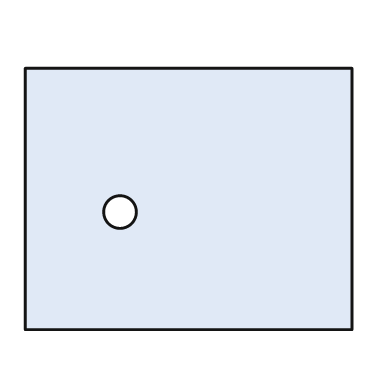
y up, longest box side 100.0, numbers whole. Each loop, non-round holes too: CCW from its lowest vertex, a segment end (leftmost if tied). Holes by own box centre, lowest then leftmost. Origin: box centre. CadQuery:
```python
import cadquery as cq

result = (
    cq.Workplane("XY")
    .moveTo(-50.0, -40.0)
    .lineTo(50.0, -40.0)
    .lineTo(50.0, 40.0)
    .lineTo(-50.0, 40.0)
    .close()
    .moveTo(-21.0, -4.0)
    .circle(5.0)
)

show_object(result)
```